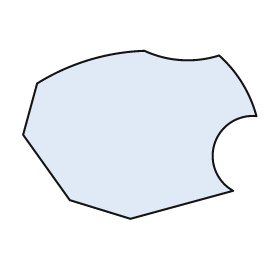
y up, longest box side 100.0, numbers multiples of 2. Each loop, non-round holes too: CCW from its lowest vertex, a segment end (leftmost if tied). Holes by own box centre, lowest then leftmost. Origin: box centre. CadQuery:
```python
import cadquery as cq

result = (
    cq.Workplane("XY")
    .moveTo(-4.0, -36.0)
    .lineTo(40.0, -24.0)
    .threePointArc((32.0, -4.0), (50.0, 8.0))
    .threePointArc((44.0, 22.0), (34.0, 34.0))
    .threePointArc((18.0, 32.0), (2.0, 36.0))
    .threePointArc((-22.0, 32.0), (-44.0, 22.0))
    .lineTo(-50.0, 0.0)
    .lineTo(-30.0, -28.0)
    .close()
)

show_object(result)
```